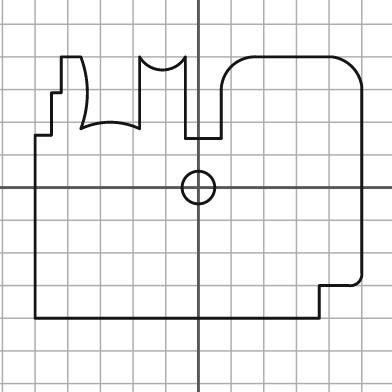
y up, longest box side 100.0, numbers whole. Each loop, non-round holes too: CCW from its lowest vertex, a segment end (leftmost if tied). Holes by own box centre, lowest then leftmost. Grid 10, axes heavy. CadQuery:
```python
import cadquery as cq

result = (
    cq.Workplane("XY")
    .moveTo(-50.0, -40.0)
    .lineTo(37.0, -40.0)
    .lineTo(37.0, -30.0)
    .lineTo(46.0, -30.0)
    .threePointArc((49.0, -29.0), (50.0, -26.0))
    .lineTo(50.0, 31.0)
    .threePointArc((47.0, 37.0), (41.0, 40.0))
    .lineTo(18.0, 40.0)
    .threePointArc((10.0, 37.0), (7.0, 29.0))
    .lineTo(7.0, 15.0)
    .lineTo(-4.0, 15.0)
    .lineTo(-4.0, 40.0)
    .threePointArc((-11.0, 36.0), (-18.0, 40.0))
    .lineTo(-18.0, 18.0)
    .threePointArc((-27.0, 20.0), (-36.0, 18.0))
    .threePointArc((-34.0, 29.0), (-36.0, 40.0))
    .lineTo(-42.0, 40.0)
    .lineTo(-42.0, 29.0)
    .lineTo(-45.0, 29.0)
    .lineTo(-45.0, 16.0)
    .lineTo(-50.0, 16.0)
    .close()
    .moveTo(0.0, 0.0)
    .circle(5.0)
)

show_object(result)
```